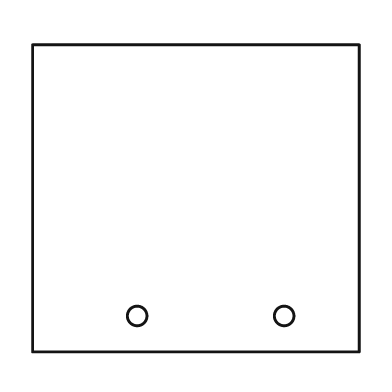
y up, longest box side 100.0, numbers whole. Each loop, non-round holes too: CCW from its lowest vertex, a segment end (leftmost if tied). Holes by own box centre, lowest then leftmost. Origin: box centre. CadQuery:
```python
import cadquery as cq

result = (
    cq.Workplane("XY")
    .moveTo(-50.0, -47.0)
    .lineTo(50.0, -47.0)
    .lineTo(50.0, 47.0)
    .lineTo(-50.0, 47.0)
    .close()
    .moveTo(-18.0, -36.0)
    .circle(3.0)
    .moveTo(27.0, -36.0)
    .circle(3.0)
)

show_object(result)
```